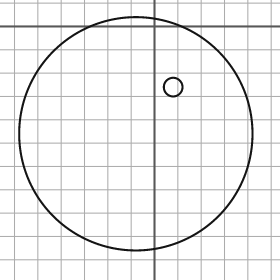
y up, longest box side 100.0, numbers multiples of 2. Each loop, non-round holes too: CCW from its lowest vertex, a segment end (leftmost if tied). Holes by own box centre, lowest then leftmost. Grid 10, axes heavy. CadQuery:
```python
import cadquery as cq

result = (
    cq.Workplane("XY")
    .moveTo(-8.0, -46.0)
    .circle(50.0)
    .moveTo(8.0, -26.0)
    .circle(4.0)
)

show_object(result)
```